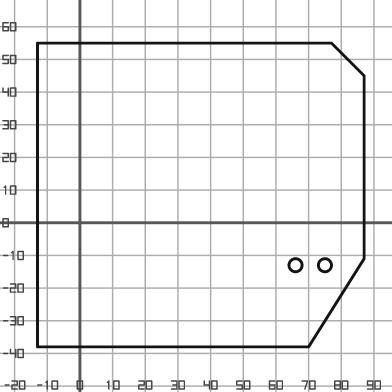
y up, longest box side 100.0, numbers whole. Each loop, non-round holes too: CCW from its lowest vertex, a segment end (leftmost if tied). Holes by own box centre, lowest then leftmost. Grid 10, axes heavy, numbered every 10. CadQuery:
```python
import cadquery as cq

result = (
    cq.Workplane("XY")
    .moveTo(-13.0, -38.0)
    .lineTo(70.0, -38.0)
    .lineTo(87.0, -11.0)
    .lineTo(87.0, 45.0)
    .lineTo(77.0, 55.0)
    .lineTo(-13.0, 55.0)
    .close()
    .moveTo(66.0, -13.0)
    .circle(2.0)
    .moveTo(75.0, -13.0)
    .circle(2.0)
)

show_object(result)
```